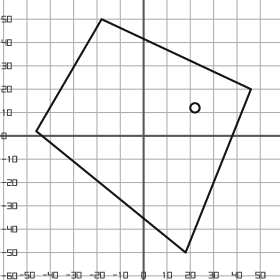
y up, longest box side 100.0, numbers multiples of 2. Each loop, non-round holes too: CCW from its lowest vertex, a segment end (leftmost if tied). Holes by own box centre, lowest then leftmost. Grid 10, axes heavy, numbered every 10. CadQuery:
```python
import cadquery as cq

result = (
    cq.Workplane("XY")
    .moveTo(18.0, -50.0)
    .lineTo(46.0, 20.0)
    .lineTo(-18.0, 50.0)
    .lineTo(-46.0, 2.0)
    .close()
    .moveTo(22.0, 12.0)
    .circle(2.0)
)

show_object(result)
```